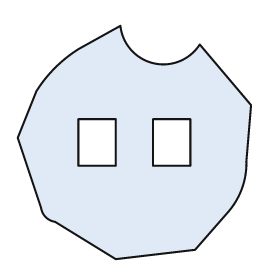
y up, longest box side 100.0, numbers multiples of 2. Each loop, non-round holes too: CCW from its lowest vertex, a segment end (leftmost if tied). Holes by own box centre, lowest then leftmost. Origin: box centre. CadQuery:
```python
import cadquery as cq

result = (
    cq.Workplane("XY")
    .moveTo(-8.0, -50.0)
    .lineTo(26.0, -46.0)
    .lineTo(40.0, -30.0)
    .threePointArc((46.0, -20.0), (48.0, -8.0))
    .lineTo(50.0, 16.0)
    .lineTo(28.0, 42.0)
    .threePointArc((8.0, 34.0), (-6.0, 50.0))
    .lineTo(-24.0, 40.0)
    .threePointArc((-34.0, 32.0), (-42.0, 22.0))
    .lineTo(-50.0, 2.0)
    .lineTo(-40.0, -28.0)
    .threePointArc((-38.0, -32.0), (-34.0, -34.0))
    .close()
    .moveTo(-24.0, -10.0)
    .lineTo(-8.0, -10.0)
    .lineTo(-8.0, 10.0)
    .lineTo(-24.0, 10.0)
    .close()
    .moveTo(8.0, -10.0)
    .lineTo(24.0, -10.0)
    .lineTo(24.0, 10.0)
    .lineTo(8.0, 10.0)
    .close()
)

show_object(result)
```